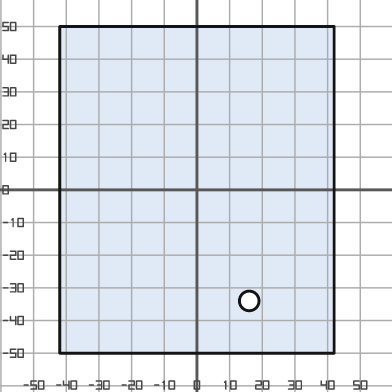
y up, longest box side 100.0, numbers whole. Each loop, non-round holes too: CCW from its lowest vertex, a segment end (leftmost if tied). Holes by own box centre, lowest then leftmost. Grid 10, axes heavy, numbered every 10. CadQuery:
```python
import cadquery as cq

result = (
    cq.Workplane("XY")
    .moveTo(-42.0, -50.0)
    .lineTo(42.0, -50.0)
    .lineTo(42.0, 50.0)
    .lineTo(-42.0, 50.0)
    .close()
    .moveTo(16.0, -34.0)
    .circle(3.0)
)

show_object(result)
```